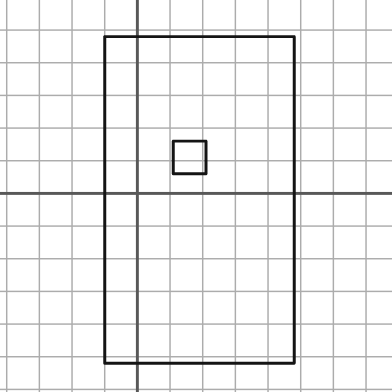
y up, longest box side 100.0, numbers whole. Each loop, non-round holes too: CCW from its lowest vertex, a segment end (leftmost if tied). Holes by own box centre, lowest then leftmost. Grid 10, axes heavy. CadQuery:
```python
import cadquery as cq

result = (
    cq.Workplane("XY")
    .moveTo(-10.0, -52.0)
    .lineTo(48.0, -52.0)
    .lineTo(48.0, 48.0)
    .lineTo(-10.0, 48.0)
    .close()
    .moveTo(11.0, 6.0)
    .lineTo(21.0, 6.0)
    .lineTo(21.0, 16.0)
    .lineTo(11.0, 16.0)
    .close()
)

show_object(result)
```